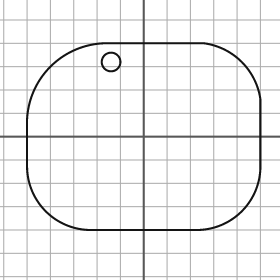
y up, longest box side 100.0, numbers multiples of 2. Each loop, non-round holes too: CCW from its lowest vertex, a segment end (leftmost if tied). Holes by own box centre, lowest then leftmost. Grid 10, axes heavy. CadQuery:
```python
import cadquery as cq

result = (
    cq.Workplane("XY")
    .moveTo(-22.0, -40.0)
    .lineTo(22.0, -40.0)
    .threePointArc((42.0, -32.0), (50.0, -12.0))
    .lineTo(50.0, 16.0)
    .threePointArc((42.0, 32.0), (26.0, 40.0))
    .lineTo(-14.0, 40.0)
    .threePointArc((-40.0, 30.0), (-50.0, 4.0))
    .lineTo(-50.0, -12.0)
    .threePointArc((-42.0, -32.0), (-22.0, -40.0))
    .close()
    .moveTo(-14.0, 32.0)
    .circle(4.0)
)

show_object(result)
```